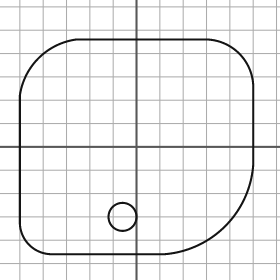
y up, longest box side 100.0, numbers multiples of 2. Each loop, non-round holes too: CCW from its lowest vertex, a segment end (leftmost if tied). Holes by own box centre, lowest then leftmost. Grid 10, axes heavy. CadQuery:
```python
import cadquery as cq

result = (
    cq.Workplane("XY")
    .moveTo(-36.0, -46.0)
    .lineTo(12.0, -46.0)
    .threePointArc((38.0, -34.0), (50.0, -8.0))
    .lineTo(50.0, 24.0)
    .threePointArc((44.0, 40.0), (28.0, 46.0))
    .lineTo(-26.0, 46.0)
    .threePointArc((-42.0, 38.0), (-50.0, 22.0))
    .lineTo(-50.0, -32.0)
    .threePointArc((-46.0, -42.0), (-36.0, -46.0))
    .close()
    .moveTo(-6.0, -30.0)
    .circle(6.0)
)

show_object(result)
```